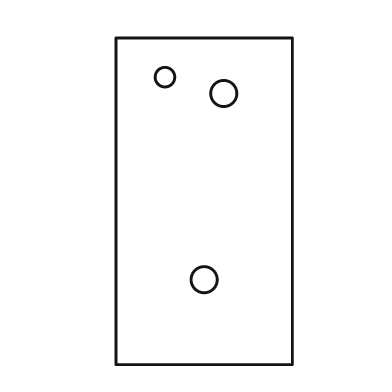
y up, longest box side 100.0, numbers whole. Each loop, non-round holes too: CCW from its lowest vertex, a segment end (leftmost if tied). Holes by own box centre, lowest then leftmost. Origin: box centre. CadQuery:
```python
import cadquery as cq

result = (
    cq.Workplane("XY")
    .moveTo(-27.0, -50.0)
    .lineTo(27.0, -50.0)
    .lineTo(27.0, 50.0)
    .lineTo(-27.0, 50.0)
    .close()
    .moveTo(0.0, -24.0)
    .circle(4.0)
    .moveTo(6.0, 33.0)
    .circle(4.0)
    .moveTo(-12.0, 38.0)
    .circle(3.0)
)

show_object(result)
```